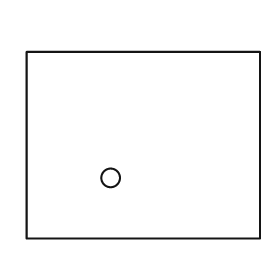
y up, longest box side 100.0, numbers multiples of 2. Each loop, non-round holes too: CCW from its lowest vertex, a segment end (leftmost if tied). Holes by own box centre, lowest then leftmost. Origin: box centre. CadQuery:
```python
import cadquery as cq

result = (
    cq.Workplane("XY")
    .moveTo(-50.0, -40.0)
    .lineTo(50.0, -40.0)
    .lineTo(50.0, 40.0)
    .lineTo(-50.0, 40.0)
    .close()
    .moveTo(-14.0, -14.0)
    .circle(4.0)
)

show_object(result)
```